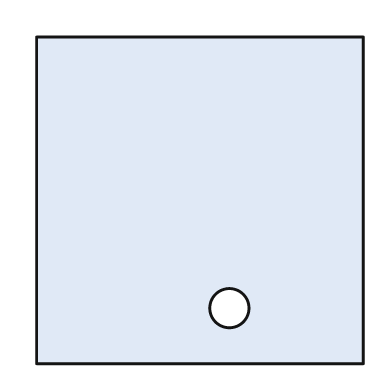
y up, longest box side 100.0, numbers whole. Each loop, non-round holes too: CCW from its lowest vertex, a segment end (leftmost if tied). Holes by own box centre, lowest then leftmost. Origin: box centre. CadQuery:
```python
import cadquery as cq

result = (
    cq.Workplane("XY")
    .moveTo(-50.0, -50.0)
    .lineTo(50.0, -50.0)
    .lineTo(50.0, 50.0)
    .lineTo(-50.0, 50.0)
    .close()
    .moveTo(9.0, -33.0)
    .circle(6.0)
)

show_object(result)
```